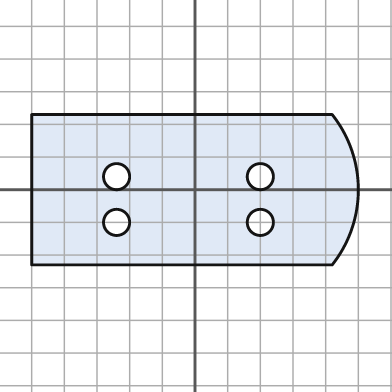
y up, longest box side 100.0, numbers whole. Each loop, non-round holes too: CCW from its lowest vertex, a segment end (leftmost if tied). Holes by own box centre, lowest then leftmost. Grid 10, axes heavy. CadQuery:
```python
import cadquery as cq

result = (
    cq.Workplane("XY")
    .moveTo(-50.0, -23.0)
    .lineTo(42.0, -23.0)
    .threePointArc((50.0, 0.0), (42.0, 23.0))
    .lineTo(-50.0, 23.0)
    .close()
    .moveTo(-24.0, -10.0)
    .circle(4.0)
    .moveTo(20.0, -10.0)
    .circle(4.0)
    .moveTo(-24.0, 4.0)
    .circle(4.0)
    .moveTo(20.0, 4.0)
    .circle(4.0)
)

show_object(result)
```